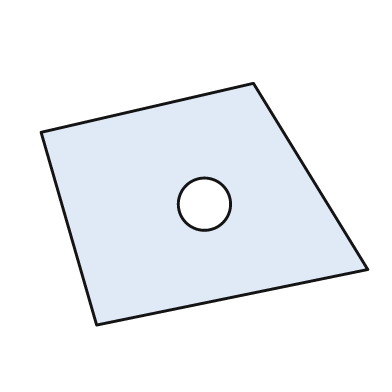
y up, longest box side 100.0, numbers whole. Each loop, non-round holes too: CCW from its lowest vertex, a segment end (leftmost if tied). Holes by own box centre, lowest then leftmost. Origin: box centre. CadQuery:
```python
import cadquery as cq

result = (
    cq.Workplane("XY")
    .moveTo(-33.0, -37.0)
    .lineTo(50.0, -20.0)
    .lineTo(15.0, 37.0)
    .lineTo(-50.0, 22.0)
    .close()
    .moveTo(0.0, 0.0)
    .circle(8.0)
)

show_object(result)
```